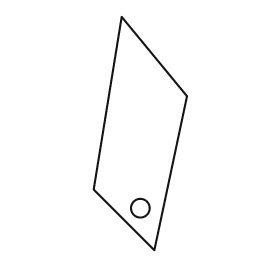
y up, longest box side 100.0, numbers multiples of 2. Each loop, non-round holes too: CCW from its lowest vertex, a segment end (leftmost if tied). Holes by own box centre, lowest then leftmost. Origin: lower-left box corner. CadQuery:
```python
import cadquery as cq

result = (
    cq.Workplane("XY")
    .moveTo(26.0, 0.0)
    .lineTo(40.0, 66.0)
    .lineTo(12.0, 100.0)
    .lineTo(0.0, 26.0)
    .close()
    .moveTo(20.0, 18.0)
    .circle(4.0)
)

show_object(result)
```